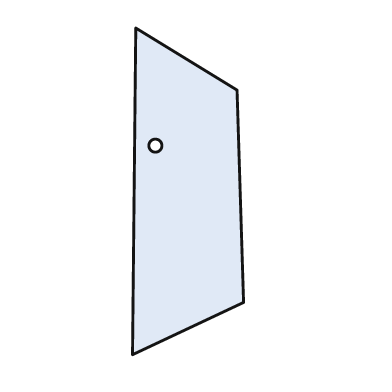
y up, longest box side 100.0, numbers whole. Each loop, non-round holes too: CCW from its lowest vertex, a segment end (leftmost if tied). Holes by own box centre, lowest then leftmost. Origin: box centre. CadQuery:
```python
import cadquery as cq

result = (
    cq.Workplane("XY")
    .moveTo(-17.0, -50.0)
    .lineTo(17.0, -34.0)
    .lineTo(15.0, 31.0)
    .lineTo(-16.0, 50.0)
    .close()
    .moveTo(-10.0, 14.0)
    .circle(2.0)
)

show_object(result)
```